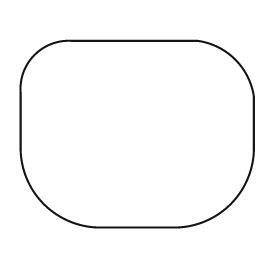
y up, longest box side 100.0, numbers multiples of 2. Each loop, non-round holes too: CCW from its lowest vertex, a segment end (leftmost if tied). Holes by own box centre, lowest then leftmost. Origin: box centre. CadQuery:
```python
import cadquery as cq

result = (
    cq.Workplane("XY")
    .moveTo(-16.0, -40.0)
    .lineTo(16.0, -40.0)
    .threePointArc((40.0, -30.0), (50.0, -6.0))
    .lineTo(50.0, 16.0)
    .threePointArc((42.0, 32.0), (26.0, 40.0))
    .lineTo(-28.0, 40.0)
    .threePointArc((-44.0, 34.0), (-50.0, 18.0))
    .lineTo(-50.0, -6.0)
    .threePointArc((-40.0, -30.0), (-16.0, -40.0))
    .close()
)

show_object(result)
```